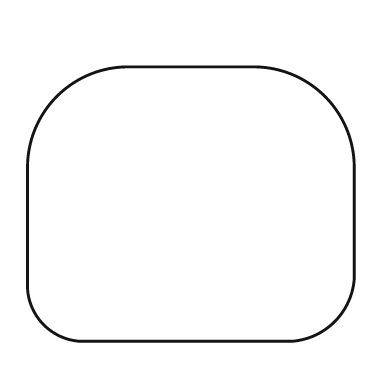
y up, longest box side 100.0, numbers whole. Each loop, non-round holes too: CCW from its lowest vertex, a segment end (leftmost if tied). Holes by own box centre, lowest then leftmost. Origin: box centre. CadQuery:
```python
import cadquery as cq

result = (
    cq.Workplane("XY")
    .moveTo(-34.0, -42.0)
    .lineTo(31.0, -42.0)
    .threePointArc((44.0, -36.0), (50.0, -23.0))
    .lineTo(50.0, 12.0)
    .threePointArc((41.0, 33.0), (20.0, 42.0))
    .lineTo(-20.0, 42.0)
    .threePointArc((-41.0, 33.0), (-50.0, 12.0))
    .lineTo(-50.0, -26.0)
    .threePointArc((-45.0, -37.0), (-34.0, -42.0))
    .close()
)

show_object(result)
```